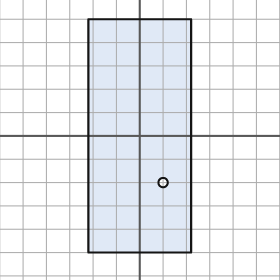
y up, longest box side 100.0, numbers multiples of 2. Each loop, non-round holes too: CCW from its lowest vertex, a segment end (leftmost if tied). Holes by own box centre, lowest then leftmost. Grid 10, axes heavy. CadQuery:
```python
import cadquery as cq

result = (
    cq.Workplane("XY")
    .moveTo(-22.0, -50.0)
    .lineTo(22.0, -50.0)
    .lineTo(22.0, 50.0)
    .lineTo(-22.0, 50.0)
    .close()
    .moveTo(10.0, -20.0)
    .circle(2.0)
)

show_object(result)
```